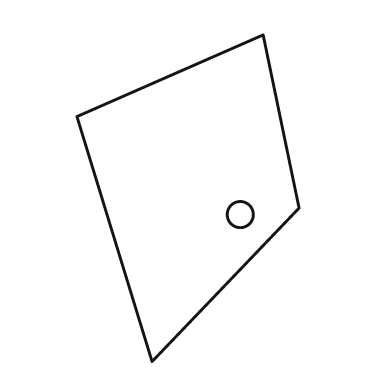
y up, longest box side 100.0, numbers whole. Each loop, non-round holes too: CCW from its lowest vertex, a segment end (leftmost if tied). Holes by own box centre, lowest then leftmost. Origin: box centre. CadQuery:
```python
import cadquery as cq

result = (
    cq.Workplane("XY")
    .moveTo(-11.0, -50.0)
    .lineTo(34.0, -3.0)
    .lineTo(23.0, 50.0)
    .lineTo(-34.0, 25.0)
    .close()
    .moveTo(16.0, -5.0)
    .circle(4.0)
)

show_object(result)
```